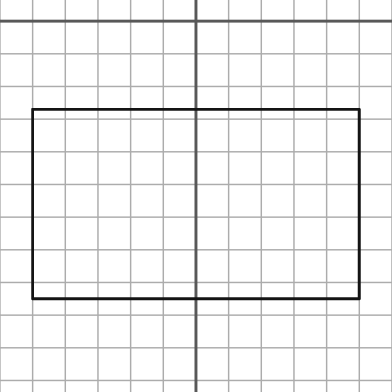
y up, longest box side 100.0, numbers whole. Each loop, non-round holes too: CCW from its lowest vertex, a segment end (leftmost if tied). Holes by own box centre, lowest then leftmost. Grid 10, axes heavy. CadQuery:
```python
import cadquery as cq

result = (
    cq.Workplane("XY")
    .moveTo(-50.0, -85.0)
    .lineTo(50.0, -85.0)
    .lineTo(50.0, -27.0)
    .lineTo(-50.0, -27.0)
    .close()
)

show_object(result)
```